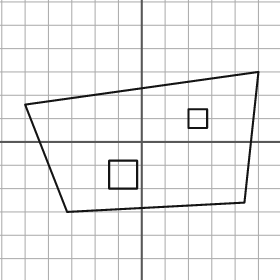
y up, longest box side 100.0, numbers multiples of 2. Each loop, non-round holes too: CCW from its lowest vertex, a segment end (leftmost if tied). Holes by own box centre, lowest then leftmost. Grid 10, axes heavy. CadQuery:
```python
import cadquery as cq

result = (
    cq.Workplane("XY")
    .moveTo(-32.0, -30.0)
    .lineTo(44.0, -26.0)
    .lineTo(50.0, 30.0)
    .lineTo(-50.0, 16.0)
    .close()
    .moveTo(-14.0, -20.0)
    .lineTo(-2.0, -20.0)
    .lineTo(-2.0, -8.0)
    .lineTo(-14.0, -8.0)
    .close()
    .moveTo(20.0, 6.0)
    .lineTo(28.0, 6.0)
    .lineTo(28.0, 14.0)
    .lineTo(20.0, 14.0)
    .close()
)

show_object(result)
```